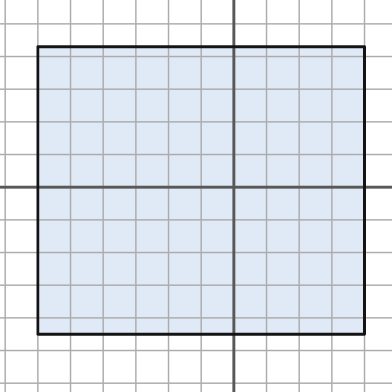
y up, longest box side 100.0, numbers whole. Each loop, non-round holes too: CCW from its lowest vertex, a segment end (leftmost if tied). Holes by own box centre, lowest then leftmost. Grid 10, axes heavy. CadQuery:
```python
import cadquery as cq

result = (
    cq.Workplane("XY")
    .moveTo(-60.0, -45.0)
    .lineTo(40.0, -45.0)
    .lineTo(40.0, 43.0)
    .lineTo(-60.0, 43.0)
    .close()
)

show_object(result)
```